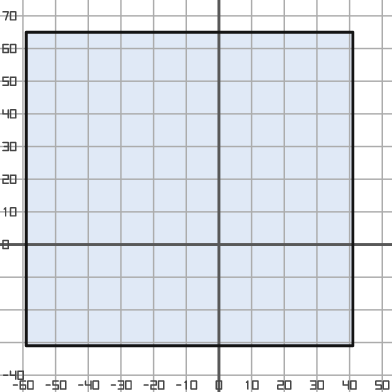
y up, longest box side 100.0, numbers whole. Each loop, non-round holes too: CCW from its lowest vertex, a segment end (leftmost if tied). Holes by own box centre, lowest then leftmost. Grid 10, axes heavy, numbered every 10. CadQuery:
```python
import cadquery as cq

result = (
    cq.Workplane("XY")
    .moveTo(-59.0, -31.0)
    .lineTo(41.0, -31.0)
    .lineTo(41.0, 65.0)
    .lineTo(-59.0, 65.0)
    .close()
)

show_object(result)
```